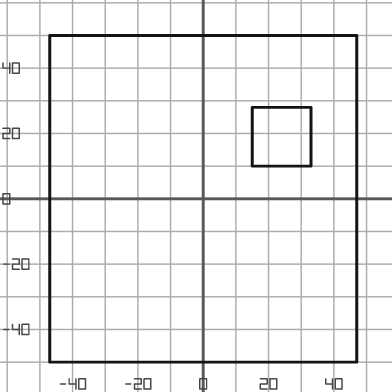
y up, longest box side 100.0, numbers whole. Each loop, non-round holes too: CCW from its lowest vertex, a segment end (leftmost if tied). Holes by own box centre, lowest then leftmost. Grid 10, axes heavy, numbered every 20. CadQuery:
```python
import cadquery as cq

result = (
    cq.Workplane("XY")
    .moveTo(-47.0, -50.0)
    .lineTo(47.0, -50.0)
    .lineTo(47.0, 50.0)
    .lineTo(-47.0, 50.0)
    .close()
    .moveTo(15.0, 10.0)
    .lineTo(33.0, 10.0)
    .lineTo(33.0, 28.0)
    .lineTo(15.0, 28.0)
    .close()
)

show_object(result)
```